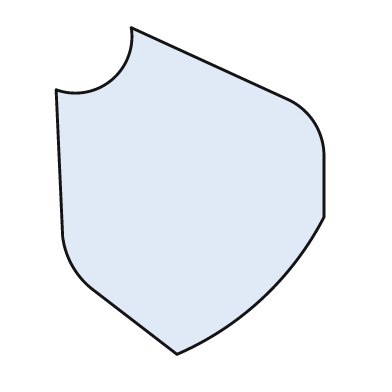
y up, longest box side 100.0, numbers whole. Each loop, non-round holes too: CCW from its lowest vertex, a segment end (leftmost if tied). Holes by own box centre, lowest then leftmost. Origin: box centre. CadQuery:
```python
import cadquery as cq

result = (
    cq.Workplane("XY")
    .moveTo(-4.0, -50.0)
    .threePointArc((22.0, -33.0), (41.0, -8.0))
    .lineTo(41.0, 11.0)
    .threePointArc((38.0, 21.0), (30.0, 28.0))
    .lineTo(-18.0, 50.0)
    .threePointArc((-24.0, 34.0), (-41.0, 31.0))
    .lineTo(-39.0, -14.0)
    .threePointArc((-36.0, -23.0), (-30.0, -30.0))
    .close()
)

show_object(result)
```